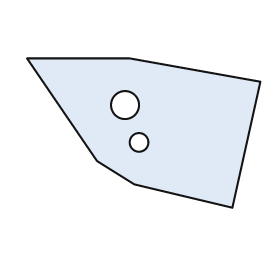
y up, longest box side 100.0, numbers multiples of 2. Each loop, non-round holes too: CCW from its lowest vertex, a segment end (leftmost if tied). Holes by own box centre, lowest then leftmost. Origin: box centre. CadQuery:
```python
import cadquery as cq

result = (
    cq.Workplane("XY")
    .moveTo(38.0, -32.0)
    .lineTo(50.0, 22.0)
    .lineTo(-6.0, 32.0)
    .lineTo(-50.0, 32.0)
    .lineTo(-20.0, -12.0)
    .lineTo(-4.0, -22.0)
    .close()
    .moveTo(-2.0, -4.0)
    .circle(4.0)
    .moveTo(-8.0, 12.0)
    .circle(6.0)
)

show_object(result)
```